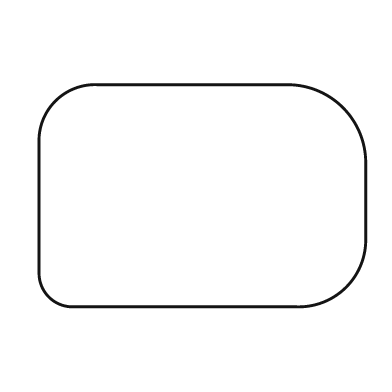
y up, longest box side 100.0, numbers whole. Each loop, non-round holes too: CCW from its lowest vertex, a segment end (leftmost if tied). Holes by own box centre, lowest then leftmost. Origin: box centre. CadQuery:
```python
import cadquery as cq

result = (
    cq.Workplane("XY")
    .moveTo(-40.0, -34.0)
    .lineTo(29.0, -34.0)
    .threePointArc((44.0, -28.0), (50.0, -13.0))
    .lineTo(50.0, 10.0)
    .threePointArc((43.0, 27.0), (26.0, 34.0))
    .lineTo(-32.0, 34.0)
    .threePointArc((-45.0, 29.0), (-50.0, 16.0))
    .lineTo(-50.0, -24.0)
    .threePointArc((-47.0, -31.0), (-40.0, -34.0))
    .close()
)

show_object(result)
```